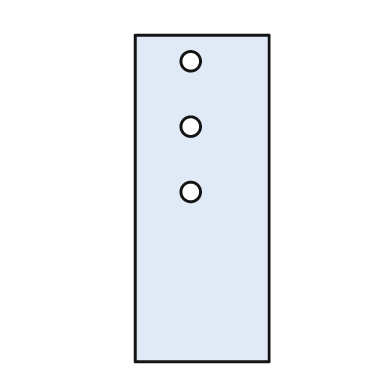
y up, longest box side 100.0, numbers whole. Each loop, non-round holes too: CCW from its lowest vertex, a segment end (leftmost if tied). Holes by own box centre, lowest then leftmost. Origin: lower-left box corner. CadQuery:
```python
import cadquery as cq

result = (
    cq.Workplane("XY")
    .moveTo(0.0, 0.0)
    .lineTo(41.0, 0.0)
    .lineTo(41.0, 100.0)
    .lineTo(0.0, 100.0)
    .close()
    .moveTo(17.0, 52.0)
    .circle(3.0)
    .moveTo(17.0, 72.0)
    .circle(3.0)
    .moveTo(17.0, 92.0)
    .circle(3.0)
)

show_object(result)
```